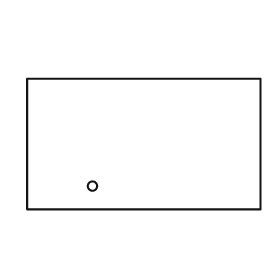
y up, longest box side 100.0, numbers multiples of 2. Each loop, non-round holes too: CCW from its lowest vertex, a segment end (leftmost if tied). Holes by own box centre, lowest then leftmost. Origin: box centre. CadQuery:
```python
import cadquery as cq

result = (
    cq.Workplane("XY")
    .moveTo(-50.0, -28.0)
    .lineTo(50.0, -28.0)
    .lineTo(50.0, 28.0)
    .lineTo(-50.0, 28.0)
    .close()
    .moveTo(-22.0, -18.0)
    .circle(2.0)
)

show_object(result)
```